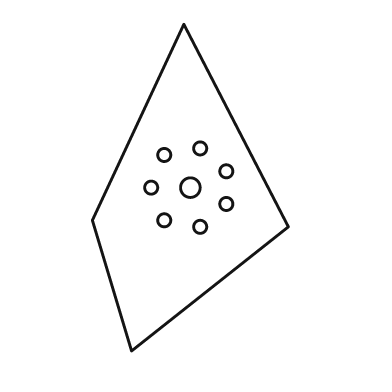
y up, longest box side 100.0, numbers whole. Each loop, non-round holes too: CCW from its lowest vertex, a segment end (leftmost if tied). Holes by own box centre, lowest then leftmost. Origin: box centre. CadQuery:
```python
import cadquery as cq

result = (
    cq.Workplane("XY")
    .moveTo(-18.0, -50.0)
    .lineTo(30.0, -12.0)
    .lineTo(-2.0, 50.0)
    .lineTo(-30.0, -10.0)
    .close()
    .moveTo(3.0, -12.0)
    .circle(2.0)
    .moveTo(-8.0, -10.0)
    .circle(2.0)
    .moveTo(11.0, -5.0)
    .circle(2.0)
    .moveTo(-12.0, 0.0)
    .circle(2.0)
    .moveTo(0.0, 0.0)
    .circle(3.0)
    .moveTo(11.0, 5.0)
    .circle(2.0)
    .moveTo(-8.0, 10.0)
    .circle(2.0)
    .moveTo(3.0, 12.0)
    .circle(2.0)
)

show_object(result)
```